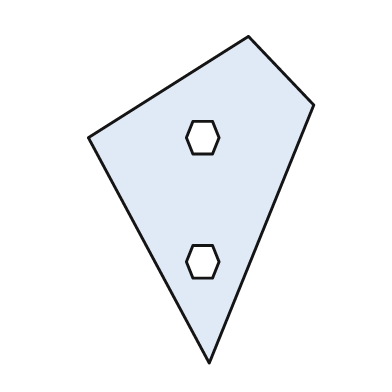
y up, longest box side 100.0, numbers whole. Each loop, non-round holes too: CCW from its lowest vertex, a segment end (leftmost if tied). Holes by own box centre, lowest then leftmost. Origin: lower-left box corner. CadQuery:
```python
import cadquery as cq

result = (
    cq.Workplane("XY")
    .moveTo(37.0, 0.0)
    .lineTo(69.0, 79.0)
    .lineTo(49.0, 100.0)
    .lineTo(0.0, 69.0)
    .close()
    .moveTo(32.0, 26.0)
    .lineTo(38.0, 26.0)
    .lineTo(40.0, 31.0)
    .lineTo(38.0, 36.0)
    .lineTo(32.0, 36.0)
    .lineTo(30.0, 31.0)
    .close()
    .moveTo(32.0, 64.0)
    .lineTo(38.0, 64.0)
    .lineTo(40.0, 69.0)
    .lineTo(38.0, 74.0)
    .lineTo(32.0, 74.0)
    .lineTo(30.0, 69.0)
    .close()
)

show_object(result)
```